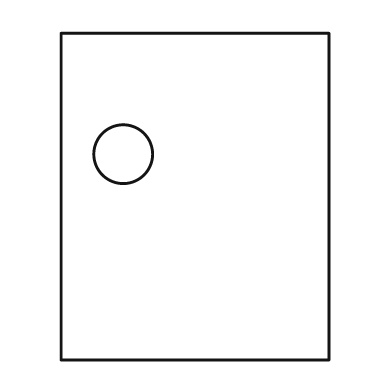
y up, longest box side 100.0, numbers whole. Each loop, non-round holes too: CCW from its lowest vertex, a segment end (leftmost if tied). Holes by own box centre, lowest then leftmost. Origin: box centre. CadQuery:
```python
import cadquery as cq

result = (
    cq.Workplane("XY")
    .moveTo(-41.0, -50.0)
    .lineTo(41.0, -50.0)
    .lineTo(41.0, 50.0)
    .lineTo(-41.0, 50.0)
    .close()
    .moveTo(-22.0, 13.0)
    .circle(9.0)
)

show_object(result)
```